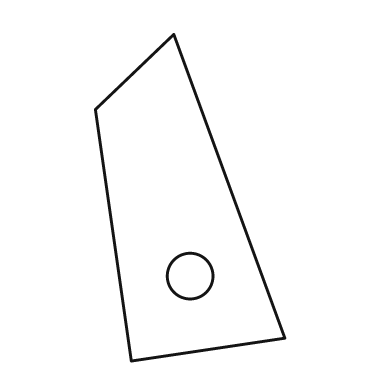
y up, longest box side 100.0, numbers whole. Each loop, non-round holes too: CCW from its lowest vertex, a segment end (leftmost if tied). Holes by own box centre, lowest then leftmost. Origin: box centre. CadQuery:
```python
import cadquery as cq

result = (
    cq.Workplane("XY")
    .moveTo(-18.0, -50.0)
    .lineTo(29.0, -43.0)
    .lineTo(-5.0, 50.0)
    .lineTo(-29.0, 27.0)
    .close()
    .moveTo(0.0, -24.0)
    .circle(7.0)
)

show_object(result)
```